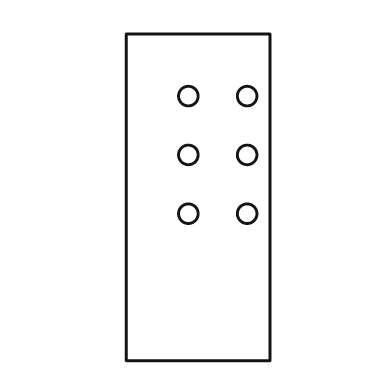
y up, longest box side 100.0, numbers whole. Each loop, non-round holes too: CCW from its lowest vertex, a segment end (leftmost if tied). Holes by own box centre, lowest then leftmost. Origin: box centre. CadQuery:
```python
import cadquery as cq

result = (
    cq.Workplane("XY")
    .moveTo(-22.0, -50.0)
    .lineTo(22.0, -50.0)
    .lineTo(22.0, 50.0)
    .lineTo(-22.0, 50.0)
    .close()
    .moveTo(-3.0, -5.0)
    .circle(3.0)
    .moveTo(15.0, -5.0)
    .circle(3.0)
    .moveTo(-3.0, 13.0)
    .circle(3.0)
    .moveTo(15.0, 13.0)
    .circle(3.0)
    .moveTo(-3.0, 31.0)
    .circle(3.0)
    .moveTo(15.0, 31.0)
    .circle(3.0)
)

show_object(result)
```